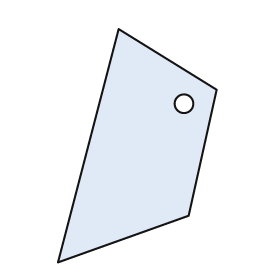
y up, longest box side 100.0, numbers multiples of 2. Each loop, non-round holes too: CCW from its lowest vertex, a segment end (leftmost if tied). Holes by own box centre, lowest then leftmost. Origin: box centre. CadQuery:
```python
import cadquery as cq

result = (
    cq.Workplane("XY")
    .moveTo(-34.0, -50.0)
    .lineTo(22.0, -30.0)
    .lineTo(34.0, 24.0)
    .lineTo(-8.0, 50.0)
    .close()
    .moveTo(20.0, 18.0)
    .circle(4.0)
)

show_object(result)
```